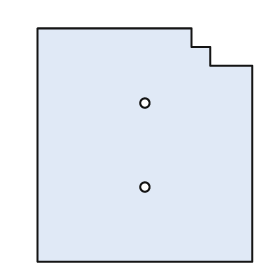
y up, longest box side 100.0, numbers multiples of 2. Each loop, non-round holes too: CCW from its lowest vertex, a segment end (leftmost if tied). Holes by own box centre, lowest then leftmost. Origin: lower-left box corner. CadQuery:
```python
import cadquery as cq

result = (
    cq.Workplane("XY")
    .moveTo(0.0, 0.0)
    .lineTo(92.0, 0.0)
    .lineTo(92.0, 84.0)
    .lineTo(74.0, 84.0)
    .lineTo(74.0, 92.0)
    .lineTo(66.0, 92.0)
    .lineTo(66.0, 100.0)
    .lineTo(0.0, 100.0)
    .close()
    .moveTo(46.0, 32.0)
    .circle(2.0)
    .moveTo(46.0, 68.0)
    .circle(2.0)
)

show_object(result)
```